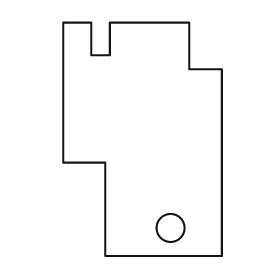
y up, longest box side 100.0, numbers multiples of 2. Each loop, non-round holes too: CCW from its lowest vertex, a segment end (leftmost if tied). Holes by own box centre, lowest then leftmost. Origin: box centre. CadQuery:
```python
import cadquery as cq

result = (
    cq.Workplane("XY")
    .moveTo(-16.0, -50.0)
    .lineTo(34.0, -50.0)
    .lineTo(34.0, 30.0)
    .lineTo(20.0, 30.0)
    .lineTo(20.0, 50.0)
    .lineTo(-14.0, 50.0)
    .lineTo(-14.0, 36.0)
    .lineTo(-22.0, 36.0)
    .lineTo(-22.0, 50.0)
    .lineTo(-34.0, 50.0)
    .lineTo(-34.0, -10.0)
    .lineTo(-16.0, -10.0)
    .close()
    .moveTo(12.0, -38.0)
    .circle(6.0)
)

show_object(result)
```